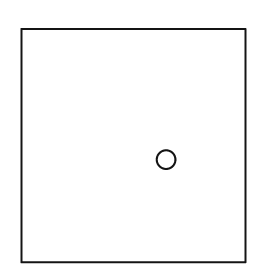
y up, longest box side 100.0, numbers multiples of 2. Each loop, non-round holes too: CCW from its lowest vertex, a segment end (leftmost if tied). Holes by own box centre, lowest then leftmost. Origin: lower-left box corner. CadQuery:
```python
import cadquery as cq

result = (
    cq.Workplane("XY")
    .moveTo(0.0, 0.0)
    .lineTo(96.0, 0.0)
    .lineTo(96.0, 100.0)
    .lineTo(0.0, 100.0)
    .close()
    .moveTo(62.0, 44.0)
    .circle(4.0)
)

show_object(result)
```